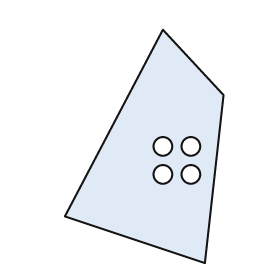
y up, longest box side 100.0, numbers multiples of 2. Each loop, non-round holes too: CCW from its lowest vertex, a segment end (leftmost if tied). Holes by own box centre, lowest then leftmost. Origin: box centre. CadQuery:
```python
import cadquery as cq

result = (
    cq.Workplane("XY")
    .moveTo(26.0, -50.0)
    .lineTo(34.0, 22.0)
    .lineTo(8.0, 50.0)
    .lineTo(-34.0, -30.0)
    .close()
    .moveTo(8.0, -12.0)
    .circle(4.0)
    .moveTo(20.0, -12.0)
    .circle(4.0)
    .moveTo(8.0, 0.0)
    .circle(4.0)
    .moveTo(20.0, 0.0)
    .circle(4.0)
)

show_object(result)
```